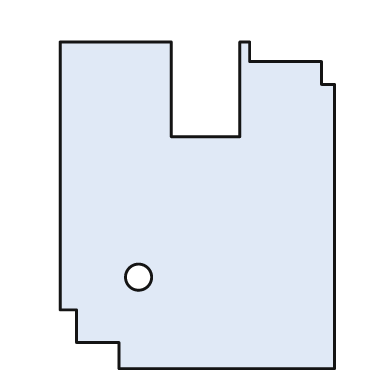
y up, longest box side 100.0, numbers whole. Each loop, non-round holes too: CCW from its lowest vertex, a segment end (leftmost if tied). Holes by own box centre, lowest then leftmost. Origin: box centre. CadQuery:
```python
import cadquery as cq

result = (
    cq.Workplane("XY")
    .moveTo(-24.0, -50.0)
    .lineTo(42.0, -50.0)
    .lineTo(42.0, 37.0)
    .lineTo(38.0, 37.0)
    .lineTo(38.0, 44.0)
    .lineTo(16.0, 44.0)
    .lineTo(16.0, 50.0)
    .lineTo(13.0, 50.0)
    .lineTo(13.0, 21.0)
    .lineTo(-8.0, 21.0)
    .lineTo(-8.0, 50.0)
    .lineTo(-42.0, 50.0)
    .lineTo(-42.0, -32.0)
    .lineTo(-37.0, -32.0)
    .lineTo(-37.0, -42.0)
    .lineTo(-24.0, -42.0)
    .close()
    .moveTo(-18.0, -22.0)
    .circle(4.0)
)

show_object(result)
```